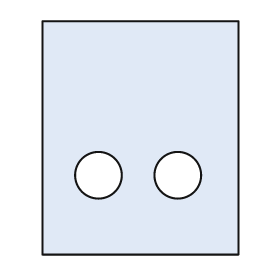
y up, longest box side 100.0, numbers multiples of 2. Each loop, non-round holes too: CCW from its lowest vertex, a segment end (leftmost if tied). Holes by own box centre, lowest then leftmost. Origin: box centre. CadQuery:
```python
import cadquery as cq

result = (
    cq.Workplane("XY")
    .moveTo(-42.0, -50.0)
    .lineTo(42.0, -50.0)
    .lineTo(42.0, 50.0)
    .lineTo(-42.0, 50.0)
    .close()
    .moveTo(-18.0, -16.0)
    .circle(10.0)
    .moveTo(16.0, -16.0)
    .circle(10.0)
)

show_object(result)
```